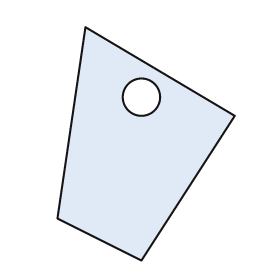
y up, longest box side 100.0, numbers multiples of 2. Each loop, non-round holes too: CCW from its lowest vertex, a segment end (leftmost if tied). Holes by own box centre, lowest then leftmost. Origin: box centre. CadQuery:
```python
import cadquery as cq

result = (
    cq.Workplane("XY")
    .moveTo(-2.0, -50.0)
    .lineTo(38.0, 12.0)
    .lineTo(-26.0, 50.0)
    .lineTo(-38.0, -32.0)
    .close()
    .moveTo(-2.0, 20.0)
    .circle(8.0)
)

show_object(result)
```